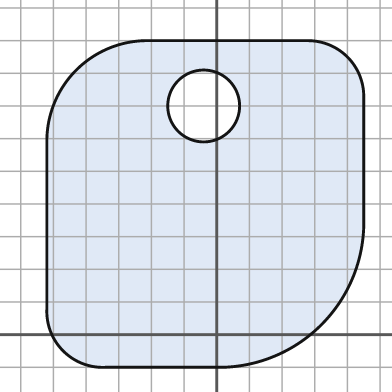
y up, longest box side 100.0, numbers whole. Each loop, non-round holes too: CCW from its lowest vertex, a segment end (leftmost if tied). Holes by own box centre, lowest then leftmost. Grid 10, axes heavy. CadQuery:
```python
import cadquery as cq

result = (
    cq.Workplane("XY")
    .moveTo(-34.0, -10.0)
    .lineTo(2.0, -10.0)
    .threePointArc((32.0, 3.0), (45.0, 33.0))
    .lineTo(45.0, 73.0)
    .threePointArc((40.0, 85.0), (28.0, 90.0))
    .lineTo(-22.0, 90.0)
    .threePointArc((-43.0, 81.0), (-52.0, 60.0))
    .lineTo(-52.0, 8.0)
    .threePointArc((-47.0, -5.0), (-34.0, -10.0))
    .close()
    .moveTo(-4.0, 70.0)
    .circle(11.0)
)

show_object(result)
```